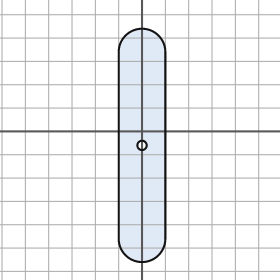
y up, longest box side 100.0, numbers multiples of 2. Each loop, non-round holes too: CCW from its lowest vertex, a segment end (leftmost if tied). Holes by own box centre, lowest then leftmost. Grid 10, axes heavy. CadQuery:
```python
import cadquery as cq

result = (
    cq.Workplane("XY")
    .moveTo(-10.0, -46.0)
    .threePointArc((0.0, -56.0), (10.0, -46.0))
    .lineTo(10.0, 34.0)
    .threePointArc((0.0, 44.0), (-10.0, 34.0))
    .close()
    .moveTo(0.0, -6.0)
    .circle(2.0)
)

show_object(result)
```